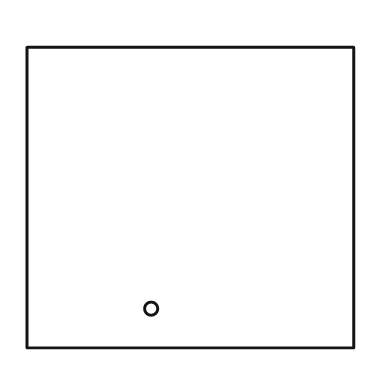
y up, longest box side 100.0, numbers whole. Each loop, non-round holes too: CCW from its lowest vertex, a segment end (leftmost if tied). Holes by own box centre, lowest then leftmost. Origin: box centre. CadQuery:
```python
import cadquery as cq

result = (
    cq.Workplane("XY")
    .moveTo(-50.0, -46.0)
    .lineTo(50.0, -46.0)
    .lineTo(50.0, 46.0)
    .lineTo(-50.0, 46.0)
    .close()
    .moveTo(-12.0, -34.0)
    .circle(2.0)
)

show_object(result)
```